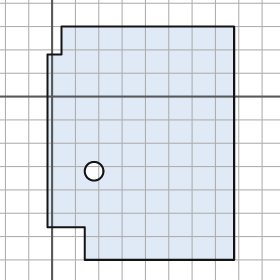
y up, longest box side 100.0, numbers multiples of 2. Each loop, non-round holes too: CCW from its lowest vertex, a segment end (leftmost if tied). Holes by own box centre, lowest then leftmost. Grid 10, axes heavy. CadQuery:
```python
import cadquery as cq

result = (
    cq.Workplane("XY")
    .moveTo(14.0, -70.0)
    .lineTo(78.0, -70.0)
    .lineTo(78.0, 30.0)
    .lineTo(4.0, 30.0)
    .lineTo(4.0, 18.0)
    .lineTo(-2.0, 18.0)
    .lineTo(-2.0, -56.0)
    .lineTo(14.0, -56.0)
    .close()
    .moveTo(18.0, -32.0)
    .circle(4.0)
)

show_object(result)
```